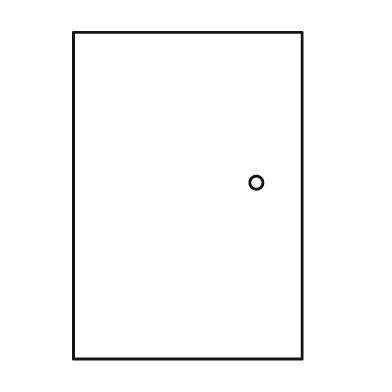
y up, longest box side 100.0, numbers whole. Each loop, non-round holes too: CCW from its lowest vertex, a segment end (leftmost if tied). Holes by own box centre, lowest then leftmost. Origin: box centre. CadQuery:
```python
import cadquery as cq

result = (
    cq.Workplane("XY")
    .moveTo(-35.0, -50.0)
    .lineTo(35.0, -50.0)
    .lineTo(35.0, 50.0)
    .lineTo(-35.0, 50.0)
    .close()
    .moveTo(21.0, 4.0)
    .circle(2.0)
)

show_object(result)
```